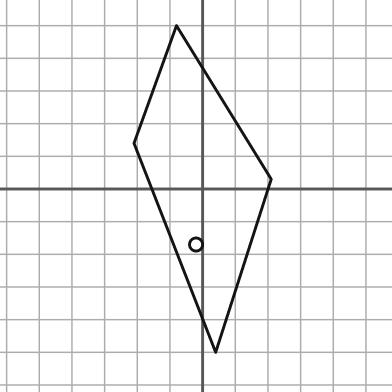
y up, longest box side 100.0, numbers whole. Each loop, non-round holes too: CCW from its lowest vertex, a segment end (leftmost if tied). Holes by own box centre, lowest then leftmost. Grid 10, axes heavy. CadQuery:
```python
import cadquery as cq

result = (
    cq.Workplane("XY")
    .moveTo(4.0, -50.0)
    .lineTo(21.0, 3.0)
    .lineTo(-8.0, 50.0)
    .lineTo(-21.0, 14.0)
    .close()
    .moveTo(-2.0, -17.0)
    .circle(2.0)
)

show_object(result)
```